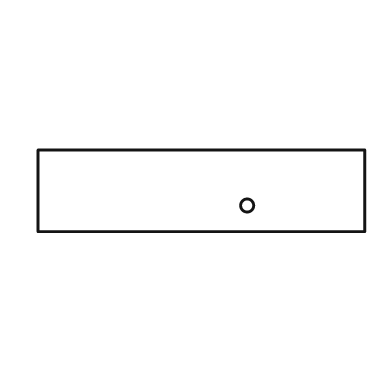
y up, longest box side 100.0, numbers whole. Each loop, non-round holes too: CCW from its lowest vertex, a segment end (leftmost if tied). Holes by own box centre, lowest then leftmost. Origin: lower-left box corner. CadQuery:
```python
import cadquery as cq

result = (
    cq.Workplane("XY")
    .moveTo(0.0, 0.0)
    .lineTo(100.0, 0.0)
    .lineTo(100.0, 25.0)
    .lineTo(0.0, 25.0)
    .close()
    .moveTo(64.0, 8.0)
    .circle(2.0)
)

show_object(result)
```